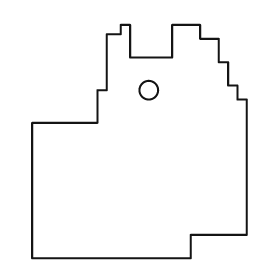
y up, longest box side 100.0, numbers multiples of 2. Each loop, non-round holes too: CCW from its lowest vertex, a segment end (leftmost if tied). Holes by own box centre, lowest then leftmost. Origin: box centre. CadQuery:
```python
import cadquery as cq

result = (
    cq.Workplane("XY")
    .moveTo(-46.0, -50.0)
    .lineTo(22.0, -50.0)
    .lineTo(22.0, -40.0)
    .lineTo(46.0, -40.0)
    .lineTo(46.0, 18.0)
    .lineTo(42.0, 18.0)
    .lineTo(42.0, 24.0)
    .lineTo(38.0, 24.0)
    .lineTo(38.0, 34.0)
    .lineTo(34.0, 34.0)
    .lineTo(34.0, 44.0)
    .lineTo(26.0, 44.0)
    .lineTo(26.0, 50.0)
    .lineTo(14.0, 50.0)
    .lineTo(14.0, 36.0)
    .lineTo(-4.0, 36.0)
    .lineTo(-4.0, 50.0)
    .lineTo(-8.0, 50.0)
    .lineTo(-8.0, 46.0)
    .lineTo(-14.0, 46.0)
    .lineTo(-14.0, 22.0)
    .lineTo(-18.0, 22.0)
    .lineTo(-18.0, 8.0)
    .lineTo(-46.0, 8.0)
    .close()
    .moveTo(4.0, 22.0)
    .circle(4.0)
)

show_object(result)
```